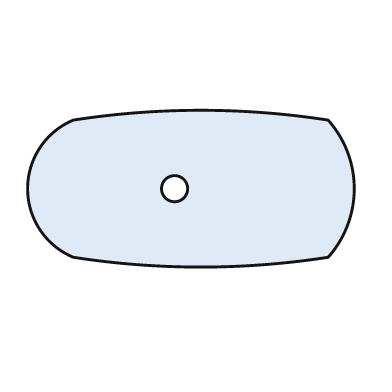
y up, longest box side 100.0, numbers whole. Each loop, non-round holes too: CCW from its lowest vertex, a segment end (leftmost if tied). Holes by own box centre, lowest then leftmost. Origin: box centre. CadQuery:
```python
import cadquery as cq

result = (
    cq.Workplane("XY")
    .moveTo(-36.0, -21.0)
    .threePointArc((3.0, -24.0), (42.0, -21.0))
    .threePointArc((50.0, 0.0), (42.0, 21.0))
    .threePointArc((3.0, 24.0), (-36.0, 21.0))
    .threePointArc((-50.0, 0.0), (-36.0, -21.0))
    .close()
    .moveTo(-5.0, 0.0)
    .circle(4.0)
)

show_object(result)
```